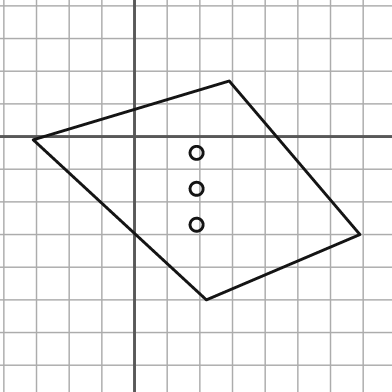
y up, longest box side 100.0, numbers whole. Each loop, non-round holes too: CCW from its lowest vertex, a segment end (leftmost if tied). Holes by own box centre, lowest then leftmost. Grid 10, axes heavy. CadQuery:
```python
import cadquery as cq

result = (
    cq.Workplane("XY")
    .moveTo(22.0, -50.0)
    .lineTo(69.0, -30.0)
    .lineTo(29.0, 17.0)
    .lineTo(-31.0, -1.0)
    .close()
    .moveTo(19.0, -27.0)
    .circle(2.0)
    .moveTo(19.0, -16.0)
    .circle(2.0)
    .moveTo(19.0, -5.0)
    .circle(2.0)
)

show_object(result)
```